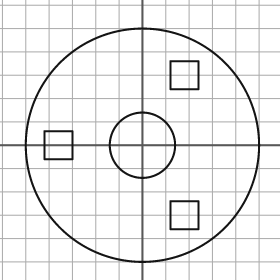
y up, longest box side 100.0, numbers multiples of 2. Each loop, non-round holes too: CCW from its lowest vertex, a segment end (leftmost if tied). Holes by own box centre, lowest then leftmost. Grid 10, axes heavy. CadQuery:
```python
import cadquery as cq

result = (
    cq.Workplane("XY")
    .moveTo(0.0, 0.0)
    .circle(50.0)
    .moveTo(12.0, -36.0)
    .lineTo(24.0, -36.0)
    .lineTo(24.0, -24.0)
    .lineTo(12.0, -24.0)
    .close()
    .moveTo(-42.0, -6.0)
    .lineTo(-30.0, -6.0)
    .lineTo(-30.0, 6.0)
    .lineTo(-42.0, 6.0)
    .close()
    .moveTo(0.0, 0.0)
    .circle(14.0)
    .moveTo(12.0, 24.0)
    .lineTo(24.0, 24.0)
    .lineTo(24.0, 36.0)
    .lineTo(12.0, 36.0)
    .close()
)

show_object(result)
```